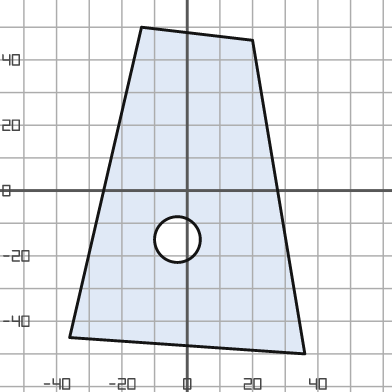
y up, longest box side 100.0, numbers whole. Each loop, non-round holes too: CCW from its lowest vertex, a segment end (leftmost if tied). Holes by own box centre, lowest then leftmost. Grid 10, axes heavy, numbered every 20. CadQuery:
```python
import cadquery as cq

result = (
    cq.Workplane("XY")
    .moveTo(36.0, -50.0)
    .lineTo(20.0, 46.0)
    .lineTo(-14.0, 50.0)
    .lineTo(-36.0, -45.0)
    .close()
    .moveTo(-3.0, -15.0)
    .circle(7.0)
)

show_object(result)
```